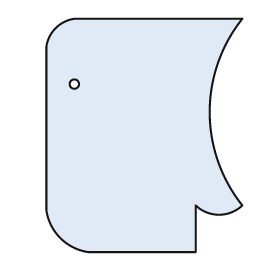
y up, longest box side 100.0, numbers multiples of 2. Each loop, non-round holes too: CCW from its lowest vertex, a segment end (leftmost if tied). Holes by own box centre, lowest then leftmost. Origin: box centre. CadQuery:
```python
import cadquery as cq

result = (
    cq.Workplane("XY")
    .moveTo(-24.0, -50.0)
    .lineTo(22.0, -50.0)
    .lineTo(22.0, -30.0)
    .threePointArc((32.0, -34.0), (42.0, -30.0))
    .threePointArc((28.0, 10.0), (42.0, 50.0))
    .lineTo(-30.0, 50.0)
    .threePointArc((-38.0, 46.0), (-42.0, 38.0))
    .lineTo(-42.0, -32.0)
    .threePointArc((-36.0, -44.0), (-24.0, -50.0))
    .close()
    .moveTo(-30.0, 22.0)
    .circle(2.0)
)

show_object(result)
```